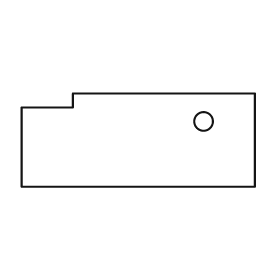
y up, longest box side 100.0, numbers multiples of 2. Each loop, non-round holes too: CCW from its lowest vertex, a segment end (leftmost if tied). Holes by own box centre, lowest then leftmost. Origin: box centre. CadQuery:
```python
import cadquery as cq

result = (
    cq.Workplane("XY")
    .moveTo(-50.0, -20.0)
    .lineTo(50.0, -20.0)
    .lineTo(50.0, 20.0)
    .lineTo(-28.0, 20.0)
    .lineTo(-28.0, 14.0)
    .lineTo(-50.0, 14.0)
    .close()
    .moveTo(28.0, 8.0)
    .circle(4.0)
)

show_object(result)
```